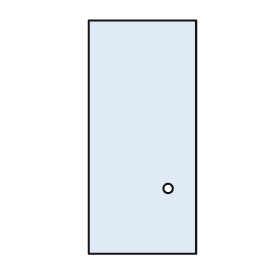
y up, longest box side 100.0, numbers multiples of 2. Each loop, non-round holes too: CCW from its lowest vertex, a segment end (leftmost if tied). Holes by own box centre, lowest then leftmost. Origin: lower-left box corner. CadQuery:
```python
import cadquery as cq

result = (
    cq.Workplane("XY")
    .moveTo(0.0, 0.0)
    .lineTo(46.0, 0.0)
    .lineTo(46.0, 100.0)
    .lineTo(0.0, 100.0)
    .close()
    .moveTo(34.0, 28.0)
    .circle(2.0)
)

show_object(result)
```